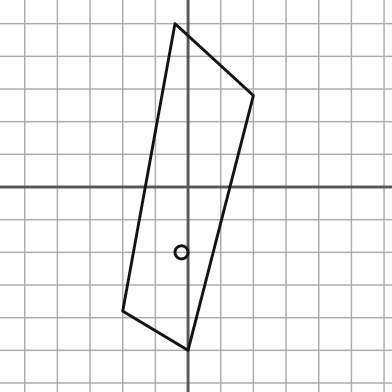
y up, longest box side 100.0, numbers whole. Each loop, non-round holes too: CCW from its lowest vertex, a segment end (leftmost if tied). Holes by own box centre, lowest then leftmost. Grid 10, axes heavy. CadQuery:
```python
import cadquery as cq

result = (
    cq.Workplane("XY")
    .moveTo(0.0, -50.0)
    .lineTo(20.0, 28.0)
    .lineTo(-4.0, 50.0)
    .lineTo(-20.0, -38.0)
    .close()
    .moveTo(-2.0, -20.0)
    .circle(2.0)
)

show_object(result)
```